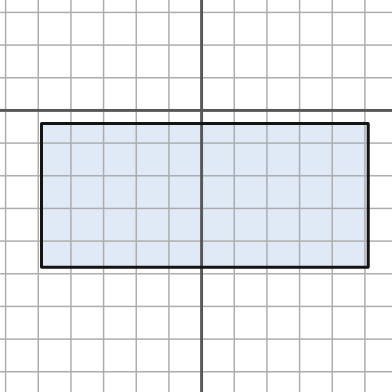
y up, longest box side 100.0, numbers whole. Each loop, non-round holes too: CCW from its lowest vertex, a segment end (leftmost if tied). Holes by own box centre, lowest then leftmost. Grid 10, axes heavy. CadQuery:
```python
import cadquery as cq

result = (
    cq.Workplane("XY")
    .moveTo(-49.0, -48.0)
    .lineTo(51.0, -48.0)
    .lineTo(51.0, -4.0)
    .lineTo(-49.0, -4.0)
    .close()
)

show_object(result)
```